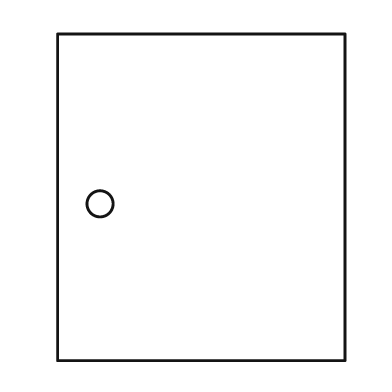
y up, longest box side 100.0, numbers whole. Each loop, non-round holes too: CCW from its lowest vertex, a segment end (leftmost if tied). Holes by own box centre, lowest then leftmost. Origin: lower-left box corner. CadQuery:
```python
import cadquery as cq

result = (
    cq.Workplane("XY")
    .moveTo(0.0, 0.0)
    .lineTo(88.0, 0.0)
    .lineTo(88.0, 100.0)
    .lineTo(0.0, 100.0)
    .close()
    .moveTo(13.0, 48.0)
    .circle(4.0)
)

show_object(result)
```